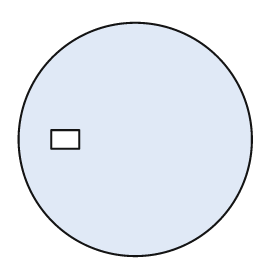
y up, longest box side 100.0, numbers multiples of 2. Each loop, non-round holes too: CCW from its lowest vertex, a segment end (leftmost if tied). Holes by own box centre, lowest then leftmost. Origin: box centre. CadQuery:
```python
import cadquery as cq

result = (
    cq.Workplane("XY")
    .moveTo(0.0, 0.0)
    .circle(50.0)
    .moveTo(-36.0, -4.0)
    .lineTo(-24.0, -4.0)
    .lineTo(-24.0, 4.0)
    .lineTo(-36.0, 4.0)
    .close()
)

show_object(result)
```